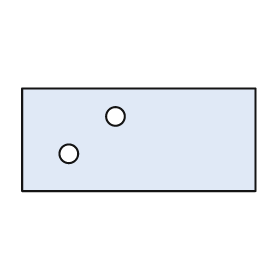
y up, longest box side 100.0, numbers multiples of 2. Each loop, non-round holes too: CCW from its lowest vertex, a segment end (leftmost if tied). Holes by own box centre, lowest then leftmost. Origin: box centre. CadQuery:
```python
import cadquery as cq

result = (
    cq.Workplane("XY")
    .moveTo(-50.0, -22.0)
    .lineTo(50.0, -22.0)
    .lineTo(50.0, 22.0)
    .lineTo(-50.0, 22.0)
    .close()
    .moveTo(-30.0, -6.0)
    .circle(4.0)
    .moveTo(-10.0, 10.0)
    .circle(4.0)
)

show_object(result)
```